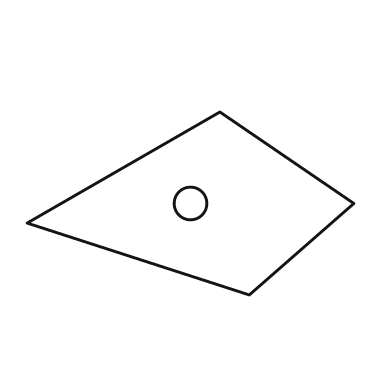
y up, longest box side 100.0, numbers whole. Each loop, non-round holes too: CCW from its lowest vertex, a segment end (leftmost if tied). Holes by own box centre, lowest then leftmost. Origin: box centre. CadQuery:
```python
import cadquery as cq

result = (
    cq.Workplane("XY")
    .moveTo(18.0, -28.0)
    .lineTo(50.0, 0.0)
    .lineTo(9.0, 28.0)
    .lineTo(-50.0, -6.0)
    .close()
    .moveTo(0.0, 0.0)
    .circle(5.0)
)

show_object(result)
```